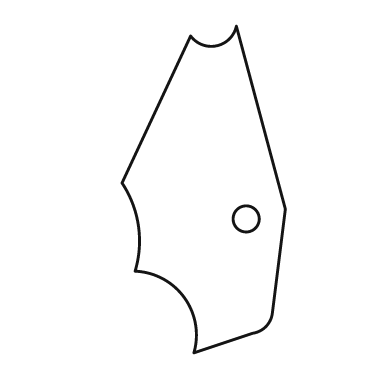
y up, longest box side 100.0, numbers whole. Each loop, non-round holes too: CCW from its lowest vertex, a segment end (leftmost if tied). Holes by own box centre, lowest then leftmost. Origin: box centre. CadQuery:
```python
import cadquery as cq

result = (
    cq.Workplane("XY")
    .moveTo(-3.0, -50.0)
    .lineTo(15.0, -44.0)
    .threePointArc((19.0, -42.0), (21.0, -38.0))
    .lineTo(25.0, -6.0)
    .lineTo(10.0, 50.0)
    .threePointArc((4.0, 44.0), (-4.0, 47.0))
    .lineTo(-25.0, 2.0)
    .threePointArc((-20.0, -11.0), (-21.0, -25.0))
    .threePointArc((-6.0, -33.0), (-3.0, -50.0))
    .close()
    .moveTo(13.0, -9.0)
    .circle(4.0)
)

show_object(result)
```